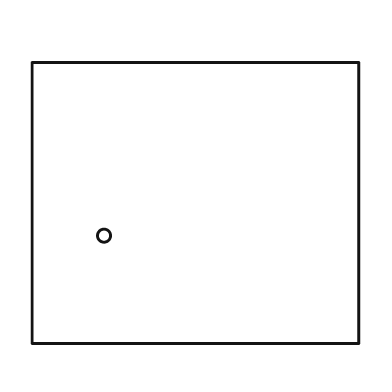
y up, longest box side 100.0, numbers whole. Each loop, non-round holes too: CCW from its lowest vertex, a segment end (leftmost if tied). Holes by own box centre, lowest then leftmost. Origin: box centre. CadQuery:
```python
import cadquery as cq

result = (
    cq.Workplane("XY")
    .moveTo(-50.0, -43.0)
    .lineTo(50.0, -43.0)
    .lineTo(50.0, 43.0)
    .lineTo(-50.0, 43.0)
    .close()
    .moveTo(-28.0, -10.0)
    .circle(2.0)
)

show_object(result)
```